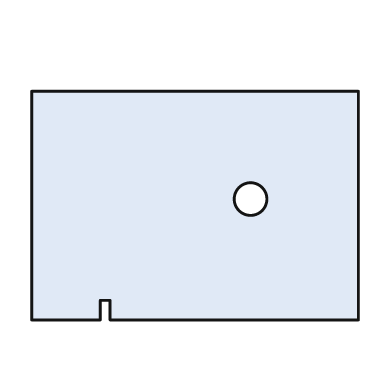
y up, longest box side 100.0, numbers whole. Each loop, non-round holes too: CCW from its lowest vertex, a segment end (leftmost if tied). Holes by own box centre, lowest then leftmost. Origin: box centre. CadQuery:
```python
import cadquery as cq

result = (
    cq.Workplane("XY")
    .moveTo(-50.0, -35.0)
    .lineTo(-29.0, -35.0)
    .lineTo(-29.0, -29.0)
    .lineTo(-26.0, -29.0)
    .lineTo(-26.0, -35.0)
    .lineTo(50.0, -35.0)
    .lineTo(50.0, 35.0)
    .lineTo(-50.0, 35.0)
    .close()
    .moveTo(17.0, 2.0)
    .circle(5.0)
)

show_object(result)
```